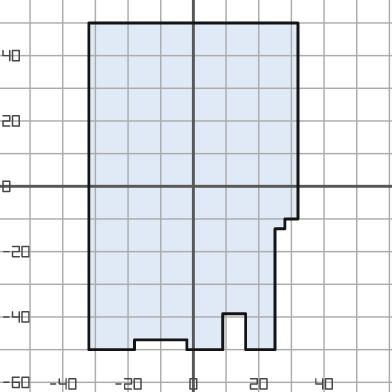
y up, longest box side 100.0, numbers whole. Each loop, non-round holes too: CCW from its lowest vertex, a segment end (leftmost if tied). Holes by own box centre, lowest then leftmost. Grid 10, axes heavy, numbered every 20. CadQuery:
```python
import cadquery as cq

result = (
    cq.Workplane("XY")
    .moveTo(-32.0, -50.0)
    .lineTo(-18.0, -50.0)
    .lineTo(-18.0, -47.0)
    .lineTo(-2.0, -47.0)
    .lineTo(-2.0, -50.0)
    .lineTo(9.0, -50.0)
    .lineTo(9.0, -39.0)
    .lineTo(16.0, -39.0)
    .lineTo(16.0, -50.0)
    .lineTo(25.0, -50.0)
    .lineTo(25.0, -13.0)
    .lineTo(28.0, -13.0)
    .lineTo(28.0, -10.0)
    .lineTo(32.0, -10.0)
    .lineTo(32.0, 50.0)
    .lineTo(-32.0, 50.0)
    .close()
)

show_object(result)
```